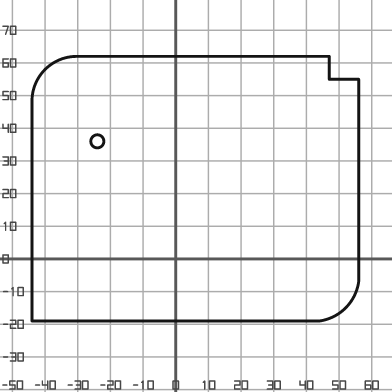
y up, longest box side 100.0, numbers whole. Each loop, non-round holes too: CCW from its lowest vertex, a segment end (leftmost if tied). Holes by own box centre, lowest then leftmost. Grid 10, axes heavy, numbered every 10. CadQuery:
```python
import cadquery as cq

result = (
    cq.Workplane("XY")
    .moveTo(-44.0, -19.0)
    .lineTo(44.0, -19.0)
    .threePointArc((52.0, -15.0), (56.0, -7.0))
    .lineTo(56.0, 55.0)
    .lineTo(47.0, 55.0)
    .lineTo(47.0, 62.0)
    .lineTo(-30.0, 62.0)
    .threePointArc((-40.0, 58.0), (-44.0, 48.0))
    .close()
    .moveTo(-24.0, 36.0)
    .circle(2.0)
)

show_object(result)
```